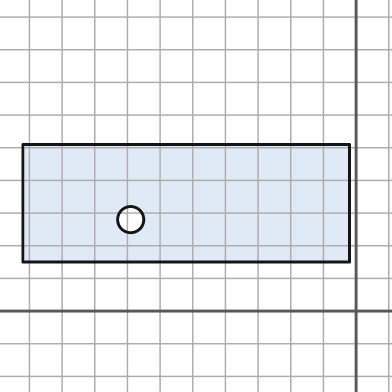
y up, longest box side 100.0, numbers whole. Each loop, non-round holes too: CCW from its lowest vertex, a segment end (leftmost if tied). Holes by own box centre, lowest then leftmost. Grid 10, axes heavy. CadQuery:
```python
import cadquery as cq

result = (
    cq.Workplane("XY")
    .moveTo(-102.0, 15.0)
    .lineTo(-2.0, 15.0)
    .lineTo(-2.0, 51.0)
    .lineTo(-102.0, 51.0)
    .close()
    .moveTo(-69.0, 28.0)
    .circle(4.0)
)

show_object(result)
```